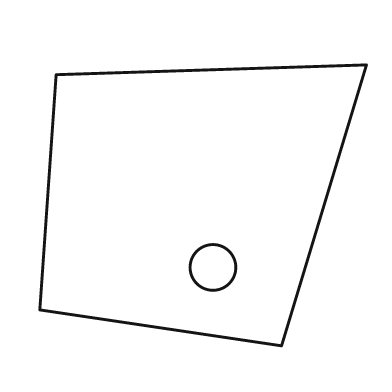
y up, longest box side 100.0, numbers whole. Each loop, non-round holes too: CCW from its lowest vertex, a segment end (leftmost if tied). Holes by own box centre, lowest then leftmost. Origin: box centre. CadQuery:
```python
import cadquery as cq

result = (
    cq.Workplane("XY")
    .moveTo(24.0, -43.0)
    .lineTo(50.0, 43.0)
    .lineTo(-45.0, 40.0)
    .lineTo(-50.0, -32.0)
    .close()
    .moveTo(3.0, -19.0)
    .circle(7.0)
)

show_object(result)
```